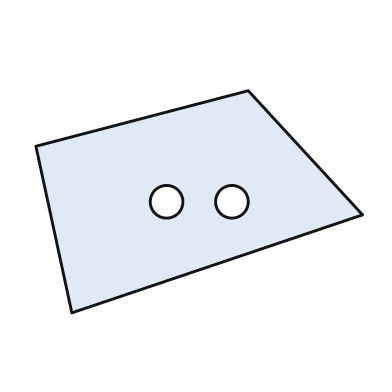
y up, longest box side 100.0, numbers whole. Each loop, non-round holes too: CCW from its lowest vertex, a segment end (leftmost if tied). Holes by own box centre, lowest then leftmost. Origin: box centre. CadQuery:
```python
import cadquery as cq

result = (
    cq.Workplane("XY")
    .moveTo(-39.0, -34.0)
    .lineTo(50.0, -4.0)
    .lineTo(15.0, 34.0)
    .lineTo(-50.0, 17.0)
    .close()
    .moveTo(-10.0, 0.0)
    .circle(5.0)
    .moveTo(10.0, 0.0)
    .circle(5.0)
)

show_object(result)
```